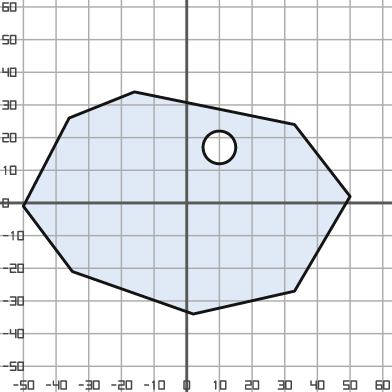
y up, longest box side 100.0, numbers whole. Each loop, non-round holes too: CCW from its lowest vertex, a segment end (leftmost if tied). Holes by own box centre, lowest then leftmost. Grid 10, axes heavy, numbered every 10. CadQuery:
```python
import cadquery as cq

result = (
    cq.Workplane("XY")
    .moveTo(2.0, -34.0)
    .lineTo(33.0, -27.0)
    .lineTo(50.0, 2.0)
    .lineTo(33.0, 24.0)
    .lineTo(-16.0, 34.0)
    .lineTo(-36.0, 26.0)
    .lineTo(-50.0, -1.0)
    .lineTo(-35.0, -21.0)
    .close()
    .moveTo(10.0, 17.0)
    .circle(5.0)
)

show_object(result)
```